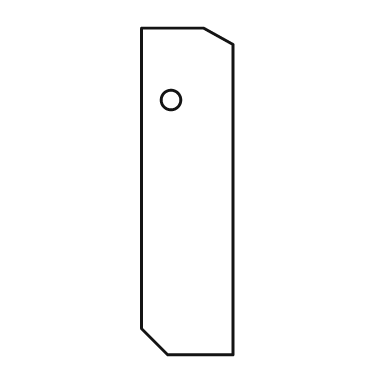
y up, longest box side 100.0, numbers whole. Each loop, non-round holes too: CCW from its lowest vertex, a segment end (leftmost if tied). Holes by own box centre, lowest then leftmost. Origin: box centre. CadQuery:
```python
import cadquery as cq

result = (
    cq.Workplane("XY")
    .moveTo(-6.0, -50.0)
    .lineTo(14.0, -50.0)
    .lineTo(14.0, 45.0)
    .lineTo(5.0, 50.0)
    .lineTo(-14.0, 50.0)
    .lineTo(-14.0, -42.0)
    .close()
    .moveTo(-5.0, 28.0)
    .circle(3.0)
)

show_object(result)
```